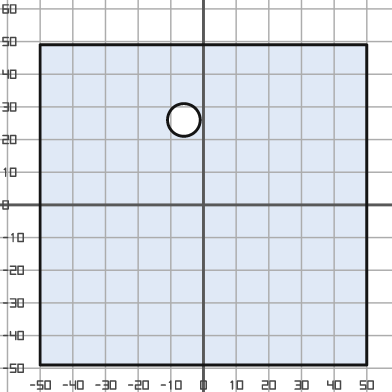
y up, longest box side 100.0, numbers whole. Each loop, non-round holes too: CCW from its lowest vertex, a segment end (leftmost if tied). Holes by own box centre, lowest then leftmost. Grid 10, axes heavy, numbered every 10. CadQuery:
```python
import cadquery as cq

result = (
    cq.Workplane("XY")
    .moveTo(-50.0, -49.0)
    .lineTo(50.0, -49.0)
    .lineTo(50.0, 49.0)
    .lineTo(-50.0, 49.0)
    .close()
    .moveTo(-6.0, 26.0)
    .circle(5.0)
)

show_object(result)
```